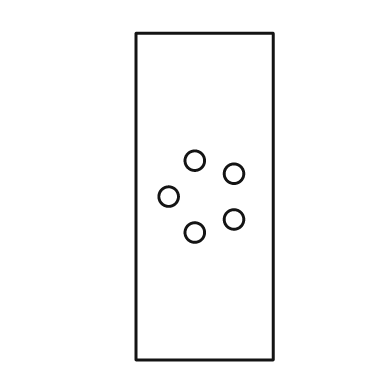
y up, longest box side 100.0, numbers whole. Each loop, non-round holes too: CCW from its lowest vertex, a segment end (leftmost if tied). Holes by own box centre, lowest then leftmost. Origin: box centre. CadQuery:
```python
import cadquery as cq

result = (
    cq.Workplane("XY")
    .moveTo(-21.0, -50.0)
    .lineTo(21.0, -50.0)
    .lineTo(21.0, 50.0)
    .lineTo(-21.0, 50.0)
    .close()
    .moveTo(-3.0, -11.0)
    .circle(3.0)
    .moveTo(9.0, -7.0)
    .circle(3.0)
    .moveTo(-11.0, 0.0)
    .circle(3.0)
    .moveTo(9.0, 7.0)
    .circle(3.0)
    .moveTo(-3.0, 11.0)
    .circle(3.0)
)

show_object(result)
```